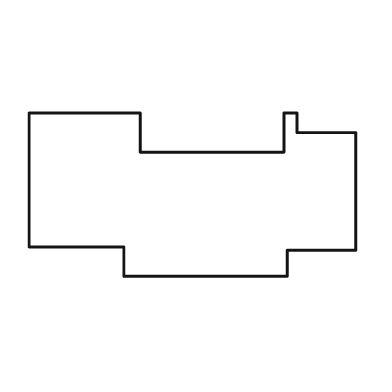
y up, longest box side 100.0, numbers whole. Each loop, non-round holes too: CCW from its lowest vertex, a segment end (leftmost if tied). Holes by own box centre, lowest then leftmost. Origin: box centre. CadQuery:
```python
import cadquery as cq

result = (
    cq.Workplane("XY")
    .moveTo(-21.0, -25.0)
    .lineTo(29.0, -25.0)
    .lineTo(29.0, -17.0)
    .lineTo(50.0, -17.0)
    .lineTo(50.0, 19.0)
    .lineTo(32.0, 19.0)
    .lineTo(32.0, 25.0)
    .lineTo(28.0, 25.0)
    .lineTo(28.0, 13.0)
    .lineTo(-16.0, 13.0)
    .lineTo(-16.0, 25.0)
    .lineTo(-50.0, 25.0)
    .lineTo(-50.0, -16.0)
    .lineTo(-21.0, -16.0)
    .close()
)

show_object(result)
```